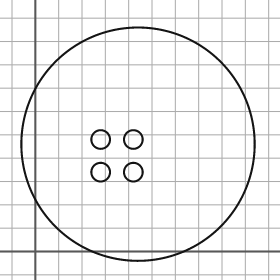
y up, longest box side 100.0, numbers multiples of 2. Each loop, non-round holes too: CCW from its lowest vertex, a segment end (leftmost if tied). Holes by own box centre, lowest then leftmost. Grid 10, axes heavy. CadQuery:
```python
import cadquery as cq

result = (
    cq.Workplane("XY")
    .moveTo(44.0, 46.0)
    .circle(50.0)
    .moveTo(28.0, 34.0)
    .circle(4.0)
    .moveTo(42.0, 34.0)
    .circle(4.0)
    .moveTo(28.0, 48.0)
    .circle(4.0)
    .moveTo(42.0, 48.0)
    .circle(4.0)
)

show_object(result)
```